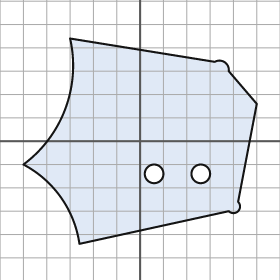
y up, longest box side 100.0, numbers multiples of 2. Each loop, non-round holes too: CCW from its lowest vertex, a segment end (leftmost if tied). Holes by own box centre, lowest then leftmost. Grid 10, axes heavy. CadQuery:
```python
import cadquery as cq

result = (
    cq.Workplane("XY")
    .moveTo(-26.0, -44.0)
    .lineTo(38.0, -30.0)
    .threePointArc((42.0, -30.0), (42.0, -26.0))
    .lineTo(50.0, 16.0)
    .lineTo(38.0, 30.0)
    .threePointArc((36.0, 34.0), (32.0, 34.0))
    .lineTo(-30.0, 44.0)
    .threePointArc((-32.0, 14.0), (-50.0, -10.0))
    .threePointArc((-34.0, -24.0), (-26.0, -44.0))
    .close()
    .moveTo(6.0, -14.0)
    .circle(4.0)
    .moveTo(26.0, -14.0)
    .circle(4.0)
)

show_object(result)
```